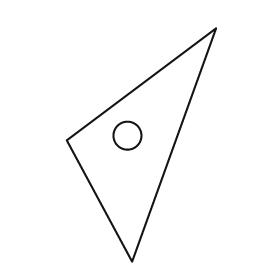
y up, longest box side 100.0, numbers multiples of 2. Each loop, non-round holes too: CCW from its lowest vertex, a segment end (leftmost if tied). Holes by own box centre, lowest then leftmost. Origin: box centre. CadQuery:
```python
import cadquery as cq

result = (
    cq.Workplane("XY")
    .moveTo(-4.0, -50.0)
    .lineTo(32.0, 50.0)
    .lineTo(-32.0, 2.0)
    .close()
    .moveTo(-6.0, 4.0)
    .circle(6.0)
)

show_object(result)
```